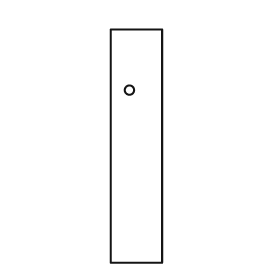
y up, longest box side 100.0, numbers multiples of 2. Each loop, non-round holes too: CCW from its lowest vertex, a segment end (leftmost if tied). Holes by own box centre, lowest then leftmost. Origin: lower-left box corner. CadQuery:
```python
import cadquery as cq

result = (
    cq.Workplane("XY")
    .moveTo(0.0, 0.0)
    .lineTo(22.0, 0.0)
    .lineTo(22.0, 100.0)
    .lineTo(0.0, 100.0)
    .close()
    .moveTo(8.0, 74.0)
    .circle(2.0)
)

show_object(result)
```